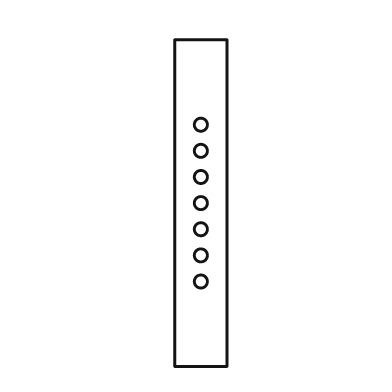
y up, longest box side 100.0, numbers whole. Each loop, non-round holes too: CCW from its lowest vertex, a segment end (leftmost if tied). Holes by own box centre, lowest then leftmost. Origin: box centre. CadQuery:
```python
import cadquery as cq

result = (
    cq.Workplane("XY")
    .moveTo(-8.0, -50.0)
    .lineTo(8.0, -50.0)
    .lineTo(8.0, 50.0)
    .lineTo(-8.0, 50.0)
    .close()
    .moveTo(0.0, -24.0)
    .circle(2.0)
    .moveTo(0.0, -16.0)
    .circle(2.0)
    .moveTo(0.0, -8.0)
    .circle(2.0)
    .moveTo(0.0, 0.0)
    .circle(2.0)
    .moveTo(0.0, 8.0)
    .circle(2.0)
    .moveTo(0.0, 16.0)
    .circle(2.0)
    .moveTo(0.0, 24.0)
    .circle(2.0)
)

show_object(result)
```